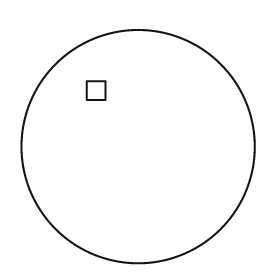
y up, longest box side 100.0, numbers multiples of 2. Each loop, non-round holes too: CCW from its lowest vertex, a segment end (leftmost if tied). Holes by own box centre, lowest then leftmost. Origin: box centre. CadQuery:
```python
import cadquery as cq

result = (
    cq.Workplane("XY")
    .moveTo(0.0, 0.0)
    .circle(50.0)
    .moveTo(-22.0, 20.0)
    .lineTo(-14.0, 20.0)
    .lineTo(-14.0, 28.0)
    .lineTo(-22.0, 28.0)
    .close()
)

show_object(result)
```